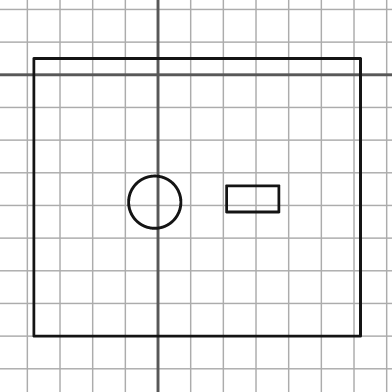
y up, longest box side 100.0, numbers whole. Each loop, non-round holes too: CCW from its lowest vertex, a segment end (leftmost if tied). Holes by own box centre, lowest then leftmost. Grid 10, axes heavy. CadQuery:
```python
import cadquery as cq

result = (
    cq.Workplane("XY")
    .moveTo(-38.0, -80.0)
    .lineTo(62.0, -80.0)
    .lineTo(62.0, 5.0)
    .lineTo(-38.0, 5.0)
    .close()
    .moveTo(-1.0, -39.0)
    .circle(8.0)
    .moveTo(21.0, -42.0)
    .lineTo(37.0, -42.0)
    .lineTo(37.0, -34.0)
    .lineTo(21.0, -34.0)
    .close()
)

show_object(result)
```